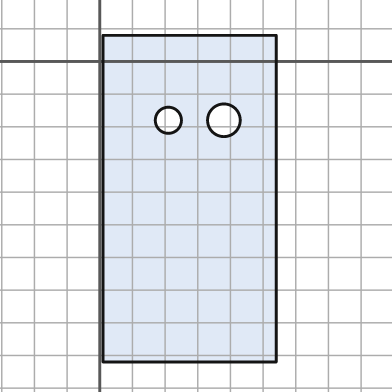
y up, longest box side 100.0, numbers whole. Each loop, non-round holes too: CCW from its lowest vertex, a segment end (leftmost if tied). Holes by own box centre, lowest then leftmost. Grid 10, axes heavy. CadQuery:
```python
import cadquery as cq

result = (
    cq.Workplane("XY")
    .moveTo(1.0, -92.0)
    .lineTo(54.0, -92.0)
    .lineTo(54.0, 8.0)
    .lineTo(1.0, 8.0)
    .close()
    .moveTo(21.0, -18.0)
    .circle(4.0)
    .moveTo(38.0, -18.0)
    .circle(5.0)
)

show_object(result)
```